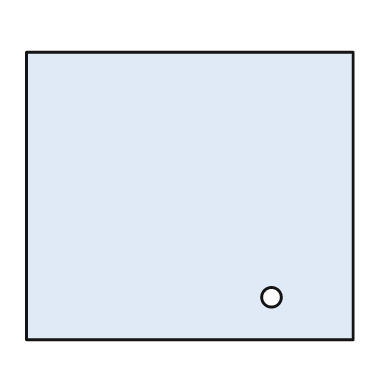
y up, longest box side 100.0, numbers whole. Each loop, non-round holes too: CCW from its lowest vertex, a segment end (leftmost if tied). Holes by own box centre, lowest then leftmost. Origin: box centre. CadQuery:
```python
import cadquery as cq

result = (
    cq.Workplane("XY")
    .moveTo(-50.0, -44.0)
    .lineTo(50.0, -44.0)
    .lineTo(50.0, 44.0)
    .lineTo(-50.0, 44.0)
    .close()
    .moveTo(25.0, -31.0)
    .circle(3.0)
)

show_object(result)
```